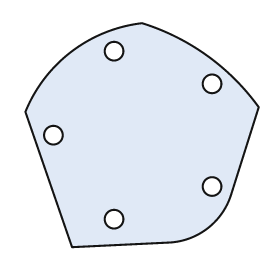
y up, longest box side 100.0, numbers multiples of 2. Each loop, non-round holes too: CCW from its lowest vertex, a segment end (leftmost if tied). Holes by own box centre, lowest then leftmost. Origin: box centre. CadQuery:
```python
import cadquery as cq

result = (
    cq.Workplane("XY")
    .moveTo(-30.0, -48.0)
    .lineTo(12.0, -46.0)
    .threePointArc((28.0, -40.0), (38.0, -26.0))
    .lineTo(50.0, 12.0)
    .threePointArc((28.0, 34.0), (0.0, 48.0))
    .threePointArc((-30.0, 36.0), (-50.0, 10.0))
    .close()
    .moveTo(-12.0, -36.0)
    .circle(4.0)
    .moveTo(30.0, -22.0)
    .circle(4.0)
    .moveTo(-38.0, 0.0)
    .circle(4.0)
    .moveTo(30.0, 22.0)
    .circle(4.0)
    .moveTo(-12.0, 36.0)
    .circle(4.0)
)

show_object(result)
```